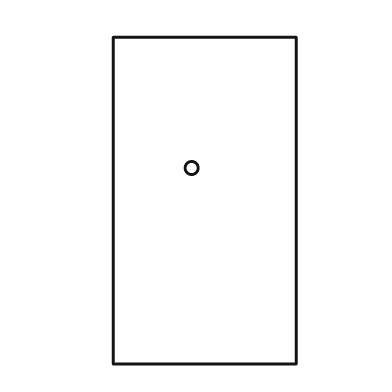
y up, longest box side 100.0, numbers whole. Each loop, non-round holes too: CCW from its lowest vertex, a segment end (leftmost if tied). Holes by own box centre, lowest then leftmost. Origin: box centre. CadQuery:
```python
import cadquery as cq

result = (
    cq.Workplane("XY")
    .moveTo(-28.0, -50.0)
    .lineTo(28.0, -50.0)
    .lineTo(28.0, 50.0)
    .lineTo(-28.0, 50.0)
    .close()
    .moveTo(-4.0, 10.0)
    .circle(2.0)
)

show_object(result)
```